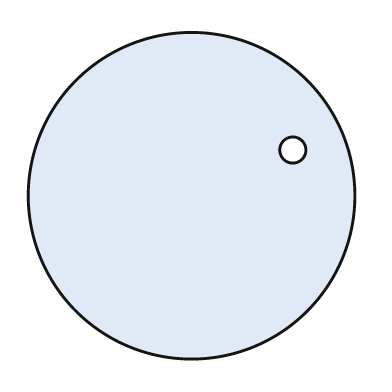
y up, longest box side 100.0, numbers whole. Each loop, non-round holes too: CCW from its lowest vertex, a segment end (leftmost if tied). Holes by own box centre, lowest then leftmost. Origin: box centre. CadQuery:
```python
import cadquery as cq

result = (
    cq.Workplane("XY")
    .moveTo(0.0, 0.0)
    .circle(50.0)
    .moveTo(31.0, 14.0)
    .circle(4.0)
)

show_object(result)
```